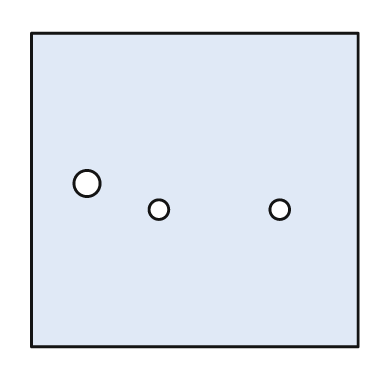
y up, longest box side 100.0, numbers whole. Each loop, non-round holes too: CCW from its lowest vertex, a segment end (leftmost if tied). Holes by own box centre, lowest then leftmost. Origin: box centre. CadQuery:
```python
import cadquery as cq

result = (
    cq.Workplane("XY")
    .moveTo(-50.0, -48.0)
    .lineTo(50.0, -48.0)
    .lineTo(50.0, 48.0)
    .lineTo(-50.0, 48.0)
    .close()
    .moveTo(-11.0, -6.0)
    .circle(3.0)
    .moveTo(26.0, -6.0)
    .circle(3.0)
    .moveTo(-33.0, 2.0)
    .circle(4.0)
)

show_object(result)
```